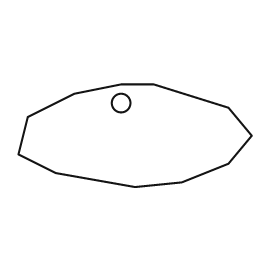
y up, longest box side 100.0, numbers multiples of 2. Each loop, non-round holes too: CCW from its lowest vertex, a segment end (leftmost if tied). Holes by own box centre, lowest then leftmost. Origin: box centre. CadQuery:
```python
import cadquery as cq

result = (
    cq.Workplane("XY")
    .moveTo(0.0, -22.0)
    .lineTo(20.0, -20.0)
    .lineTo(40.0, -12.0)
    .lineTo(50.0, 0.0)
    .lineTo(40.0, 12.0)
    .lineTo(8.0, 22.0)
    .lineTo(-6.0, 22.0)
    .lineTo(-26.0, 18.0)
    .lineTo(-46.0, 8.0)
    .lineTo(-50.0, -8.0)
    .lineTo(-34.0, -16.0)
    .close()
    .moveTo(-6.0, 14.0)
    .circle(4.0)
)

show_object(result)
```